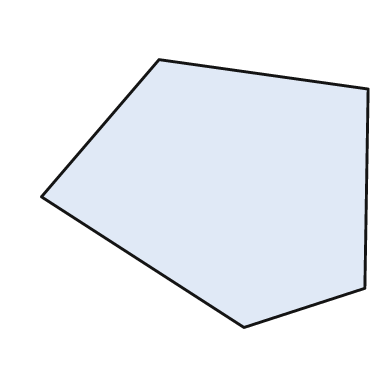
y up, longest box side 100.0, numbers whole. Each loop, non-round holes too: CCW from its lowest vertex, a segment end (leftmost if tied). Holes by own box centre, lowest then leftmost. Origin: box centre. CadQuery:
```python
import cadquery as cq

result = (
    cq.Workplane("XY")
    .moveTo(12.0, -41.0)
    .lineTo(49.0, -29.0)
    .lineTo(50.0, 32.0)
    .lineTo(-14.0, 41.0)
    .lineTo(-50.0, -1.0)
    .close()
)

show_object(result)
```